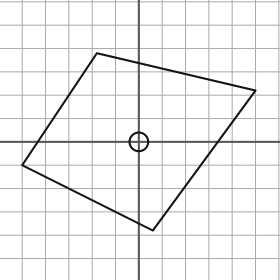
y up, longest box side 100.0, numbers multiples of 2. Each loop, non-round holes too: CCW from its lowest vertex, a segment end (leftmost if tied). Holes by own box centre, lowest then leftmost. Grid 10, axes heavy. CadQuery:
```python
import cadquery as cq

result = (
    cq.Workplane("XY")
    .moveTo(6.0, -38.0)
    .lineTo(50.0, 22.0)
    .lineTo(-18.0, 38.0)
    .lineTo(-50.0, -10.0)
    .close()
    .moveTo(0.0, 0.0)
    .circle(4.0)
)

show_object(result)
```